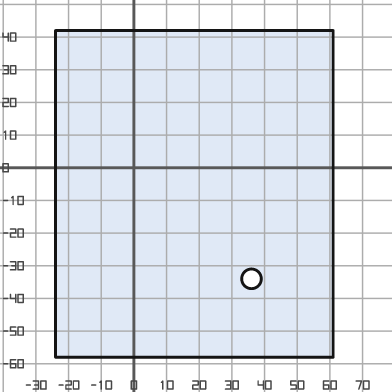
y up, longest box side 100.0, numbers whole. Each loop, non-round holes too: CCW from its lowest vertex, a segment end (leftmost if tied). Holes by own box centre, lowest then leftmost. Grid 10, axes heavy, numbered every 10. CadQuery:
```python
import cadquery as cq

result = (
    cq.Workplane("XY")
    .moveTo(-24.0, -58.0)
    .lineTo(61.0, -58.0)
    .lineTo(61.0, 42.0)
    .lineTo(-24.0, 42.0)
    .close()
    .moveTo(36.0, -34.0)
    .circle(3.0)
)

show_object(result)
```